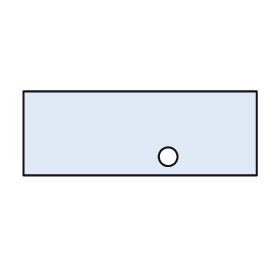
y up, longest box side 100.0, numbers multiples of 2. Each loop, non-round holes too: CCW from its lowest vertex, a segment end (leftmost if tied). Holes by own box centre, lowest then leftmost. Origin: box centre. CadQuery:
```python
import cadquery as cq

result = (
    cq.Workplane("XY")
    .moveTo(-50.0, -18.0)
    .lineTo(50.0, -18.0)
    .lineTo(50.0, 18.0)
    .lineTo(-50.0, 18.0)
    .close()
    .moveTo(12.0, -10.0)
    .circle(4.0)
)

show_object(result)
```